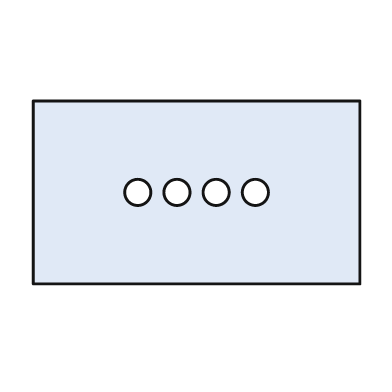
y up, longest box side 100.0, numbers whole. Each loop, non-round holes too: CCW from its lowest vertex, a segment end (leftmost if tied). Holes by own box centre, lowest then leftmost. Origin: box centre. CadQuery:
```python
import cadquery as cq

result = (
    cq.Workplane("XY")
    .moveTo(-50.0, -28.0)
    .lineTo(50.0, -28.0)
    .lineTo(50.0, 28.0)
    .lineTo(-50.0, 28.0)
    .close()
    .moveTo(-18.0, 0.0)
    .circle(4.0)
    .moveTo(-6.0, 0.0)
    .circle(4.0)
    .moveTo(6.0, 0.0)
    .circle(4.0)
    .moveTo(18.0, 0.0)
    .circle(4.0)
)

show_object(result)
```